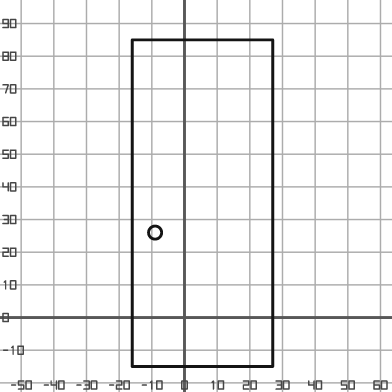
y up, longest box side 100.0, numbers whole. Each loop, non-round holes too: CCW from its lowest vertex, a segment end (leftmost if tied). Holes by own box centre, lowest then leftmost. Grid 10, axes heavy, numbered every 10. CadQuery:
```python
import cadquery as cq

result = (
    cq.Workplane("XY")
    .moveTo(-16.0, -15.0)
    .lineTo(27.0, -15.0)
    .lineTo(27.0, 85.0)
    .lineTo(-16.0, 85.0)
    .close()
    .moveTo(-9.0, 26.0)
    .circle(2.0)
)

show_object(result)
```